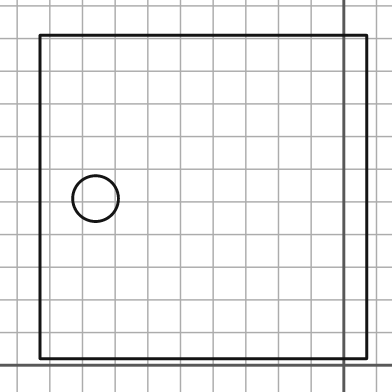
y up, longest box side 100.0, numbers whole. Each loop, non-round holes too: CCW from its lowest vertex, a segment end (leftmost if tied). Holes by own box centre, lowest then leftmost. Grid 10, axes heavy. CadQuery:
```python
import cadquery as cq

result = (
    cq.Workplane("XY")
    .moveTo(-93.0, 2.0)
    .lineTo(7.0, 2.0)
    .lineTo(7.0, 101.0)
    .lineTo(-93.0, 101.0)
    .close()
    .moveTo(-76.0, 51.0)
    .circle(7.0)
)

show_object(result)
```